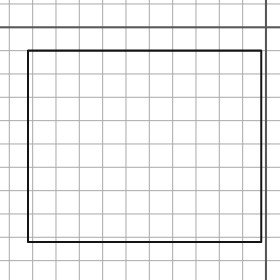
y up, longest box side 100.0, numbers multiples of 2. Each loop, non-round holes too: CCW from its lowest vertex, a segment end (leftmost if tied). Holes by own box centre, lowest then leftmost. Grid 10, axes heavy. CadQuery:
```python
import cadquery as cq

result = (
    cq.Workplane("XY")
    .moveTo(-102.0, -92.0)
    .lineTo(-2.0, -92.0)
    .lineTo(-2.0, -10.0)
    .lineTo(-102.0, -10.0)
    .close()
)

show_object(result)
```